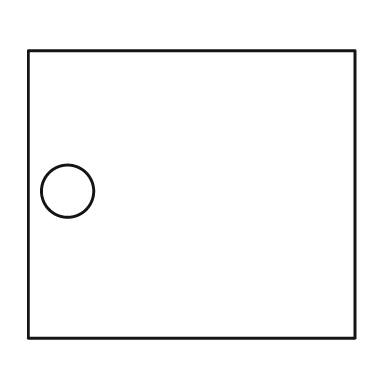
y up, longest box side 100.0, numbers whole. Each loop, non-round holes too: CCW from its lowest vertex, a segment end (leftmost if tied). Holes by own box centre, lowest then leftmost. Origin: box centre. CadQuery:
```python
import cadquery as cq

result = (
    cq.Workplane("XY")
    .moveTo(-50.0, -44.0)
    .lineTo(50.0, -44.0)
    .lineTo(50.0, 44.0)
    .lineTo(-50.0, 44.0)
    .close()
    .moveTo(-38.0, 1.0)
    .circle(8.0)
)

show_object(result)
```